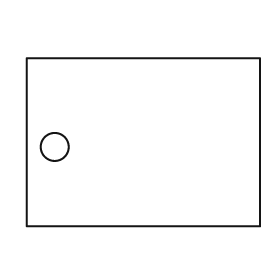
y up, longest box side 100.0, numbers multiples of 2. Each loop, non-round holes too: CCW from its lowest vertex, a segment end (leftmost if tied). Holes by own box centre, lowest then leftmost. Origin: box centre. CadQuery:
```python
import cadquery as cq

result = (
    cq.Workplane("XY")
    .moveTo(-50.0, -36.0)
    .lineTo(50.0, -36.0)
    .lineTo(50.0, 36.0)
    .lineTo(-50.0, 36.0)
    .close()
    .moveTo(-38.0, -2.0)
    .circle(6.0)
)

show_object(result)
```